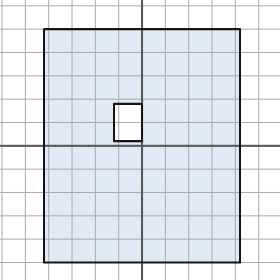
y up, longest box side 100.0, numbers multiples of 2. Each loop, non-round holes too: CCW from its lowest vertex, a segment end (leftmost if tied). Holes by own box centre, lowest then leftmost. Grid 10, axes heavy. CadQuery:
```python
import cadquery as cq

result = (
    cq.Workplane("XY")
    .moveTo(-42.0, -50.0)
    .lineTo(42.0, -50.0)
    .lineTo(42.0, 50.0)
    .lineTo(-42.0, 50.0)
    .close()
    .moveTo(-12.0, 2.0)
    .lineTo(0.0, 2.0)
    .lineTo(0.0, 18.0)
    .lineTo(-12.0, 18.0)
    .close()
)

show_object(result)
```